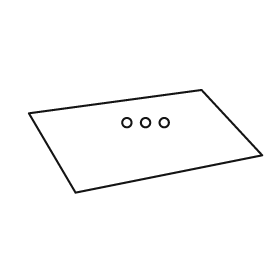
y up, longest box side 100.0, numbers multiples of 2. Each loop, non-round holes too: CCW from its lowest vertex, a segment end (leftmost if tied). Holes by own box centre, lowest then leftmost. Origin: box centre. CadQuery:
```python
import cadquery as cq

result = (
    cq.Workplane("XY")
    .moveTo(-30.0, -22.0)
    .lineTo(50.0, -6.0)
    .lineTo(24.0, 22.0)
    .lineTo(-50.0, 12.0)
    .close()
    .moveTo(-8.0, 8.0)
    .circle(2.0)
    .moveTo(0.0, 8.0)
    .circle(2.0)
    .moveTo(8.0, 8.0)
    .circle(2.0)
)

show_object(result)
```